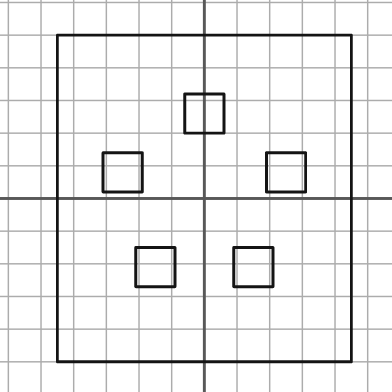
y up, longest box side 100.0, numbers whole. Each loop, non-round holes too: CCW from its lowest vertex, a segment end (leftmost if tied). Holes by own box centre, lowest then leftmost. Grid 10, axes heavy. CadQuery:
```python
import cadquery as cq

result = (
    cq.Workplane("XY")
    .moveTo(-45.0, -50.0)
    .lineTo(45.0, -50.0)
    .lineTo(45.0, 50.0)
    .lineTo(-45.0, 50.0)
    .close()
    .moveTo(-21.0, -27.0)
    .lineTo(-9.0, -27.0)
    .lineTo(-9.0, -15.0)
    .lineTo(-21.0, -15.0)
    .close()
    .moveTo(9.0, -27.0)
    .lineTo(21.0, -27.0)
    .lineTo(21.0, -15.0)
    .lineTo(9.0, -15.0)
    .close()
    .moveTo(-31.0, 2.0)
    .lineTo(-19.0, 2.0)
    .lineTo(-19.0, 14.0)
    .lineTo(-31.0, 14.0)
    .close()
    .moveTo(19.0, 2.0)
    .lineTo(31.0, 2.0)
    .lineTo(31.0, 14.0)
    .lineTo(19.0, 14.0)
    .close()
    .moveTo(-6.0, 20.0)
    .lineTo(6.0, 20.0)
    .lineTo(6.0, 32.0)
    .lineTo(-6.0, 32.0)
    .close()
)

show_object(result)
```